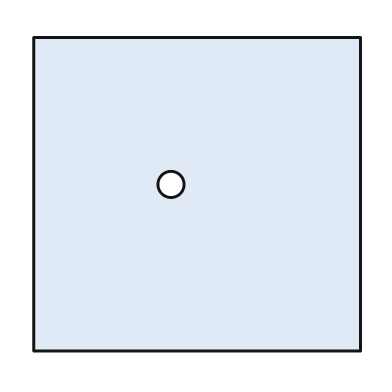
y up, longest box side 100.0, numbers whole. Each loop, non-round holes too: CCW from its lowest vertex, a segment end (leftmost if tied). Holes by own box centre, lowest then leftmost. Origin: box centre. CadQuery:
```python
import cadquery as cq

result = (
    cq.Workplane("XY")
    .moveTo(-50.0, -48.0)
    .lineTo(50.0, -48.0)
    .lineTo(50.0, 48.0)
    .lineTo(-50.0, 48.0)
    .close()
    .moveTo(-8.0, 3.0)
    .circle(4.0)
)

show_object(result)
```